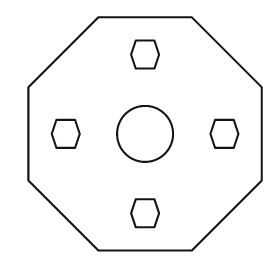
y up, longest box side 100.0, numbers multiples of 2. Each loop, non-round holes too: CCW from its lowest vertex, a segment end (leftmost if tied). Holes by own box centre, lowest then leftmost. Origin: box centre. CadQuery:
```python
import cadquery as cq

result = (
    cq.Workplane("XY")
    .moveTo(-20.0, -50.0)
    .lineTo(20.0, -50.0)
    .lineTo(50.0, -20.0)
    .lineTo(50.0, 20.0)
    .lineTo(20.0, 50.0)
    .lineTo(-20.0, 50.0)
    .lineTo(-50.0, 20.0)
    .lineTo(-50.0, -20.0)
    .close()
    .moveTo(-4.0, -40.0)
    .lineTo(4.0, -40.0)
    .lineTo(6.0, -34.0)
    .lineTo(4.0, -28.0)
    .lineTo(-4.0, -28.0)
    .lineTo(-6.0, -34.0)
    .close()
    .moveTo(-38.0, -6.0)
    .lineTo(-30.0, -6.0)
    .lineTo(-28.0, 0.0)
    .lineTo(-30.0, 6.0)
    .lineTo(-38.0, 6.0)
    .lineTo(-40.0, 0.0)
    .close()
    .moveTo(0.0, 0.0)
    .circle(12.0)
    .moveTo(30.0, -6.0)
    .lineTo(38.0, -6.0)
    .lineTo(40.0, 0.0)
    .lineTo(38.0, 6.0)
    .lineTo(30.0, 6.0)
    .lineTo(28.0, 0.0)
    .close()
    .moveTo(-4.0, 28.0)
    .lineTo(4.0, 28.0)
    .lineTo(6.0, 34.0)
    .lineTo(4.0, 40.0)
    .lineTo(-4.0, 40.0)
    .lineTo(-6.0, 34.0)
    .close()
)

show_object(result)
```